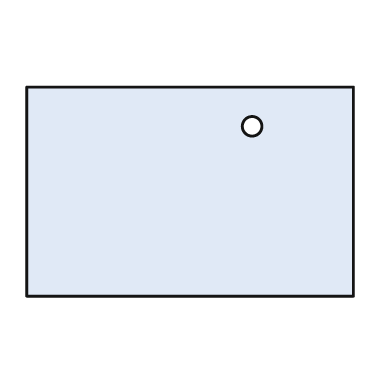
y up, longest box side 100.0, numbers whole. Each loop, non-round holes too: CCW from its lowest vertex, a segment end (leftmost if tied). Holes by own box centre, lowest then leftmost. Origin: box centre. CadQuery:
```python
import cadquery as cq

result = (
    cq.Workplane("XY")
    .moveTo(-50.0, -32.0)
    .lineTo(50.0, -32.0)
    .lineTo(50.0, 32.0)
    .lineTo(-50.0, 32.0)
    .close()
    .moveTo(19.0, 20.0)
    .circle(3.0)
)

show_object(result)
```